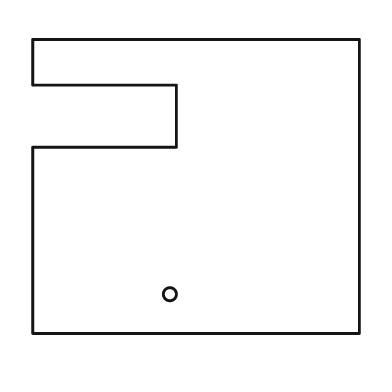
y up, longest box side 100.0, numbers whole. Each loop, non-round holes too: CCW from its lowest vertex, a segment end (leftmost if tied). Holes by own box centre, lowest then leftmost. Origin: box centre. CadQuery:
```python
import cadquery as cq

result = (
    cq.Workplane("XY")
    .moveTo(-50.0, -45.0)
    .lineTo(50.0, -45.0)
    .lineTo(50.0, 45.0)
    .lineTo(-50.0, 45.0)
    .lineTo(-50.0, 31.0)
    .lineTo(-6.0, 31.0)
    .lineTo(-6.0, 12.0)
    .lineTo(-50.0, 12.0)
    .close()
    .moveTo(-8.0, -33.0)
    .circle(2.0)
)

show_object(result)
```